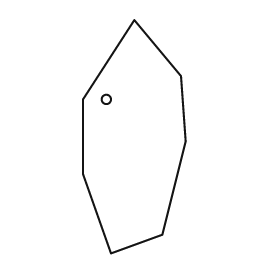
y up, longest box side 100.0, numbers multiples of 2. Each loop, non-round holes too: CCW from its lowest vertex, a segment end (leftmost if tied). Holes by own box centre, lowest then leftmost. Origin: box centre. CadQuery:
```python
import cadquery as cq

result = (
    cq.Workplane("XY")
    .moveTo(-10.0, -50.0)
    .lineTo(12.0, -42.0)
    .lineTo(22.0, -2.0)
    .lineTo(20.0, 26.0)
    .lineTo(0.0, 50.0)
    .lineTo(-22.0, 16.0)
    .lineTo(-22.0, -16.0)
    .close()
    .moveTo(-12.0, 16.0)
    .circle(2.0)
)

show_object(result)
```